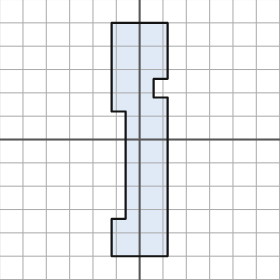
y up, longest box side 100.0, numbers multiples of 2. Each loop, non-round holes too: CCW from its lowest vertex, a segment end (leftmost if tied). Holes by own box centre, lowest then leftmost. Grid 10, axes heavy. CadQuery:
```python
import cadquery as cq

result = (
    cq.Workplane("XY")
    .moveTo(-12.0, -50.0)
    .lineTo(12.0, -50.0)
    .lineTo(12.0, 18.0)
    .lineTo(6.0, 18.0)
    .lineTo(6.0, 26.0)
    .lineTo(12.0, 26.0)
    .lineTo(12.0, 50.0)
    .lineTo(-12.0, 50.0)
    .lineTo(-12.0, 12.0)
    .lineTo(-6.0, 12.0)
    .lineTo(-6.0, -34.0)
    .lineTo(-12.0, -34.0)
    .close()
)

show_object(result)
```